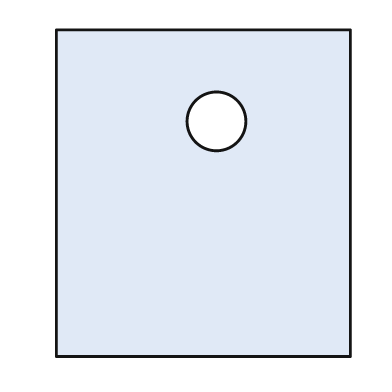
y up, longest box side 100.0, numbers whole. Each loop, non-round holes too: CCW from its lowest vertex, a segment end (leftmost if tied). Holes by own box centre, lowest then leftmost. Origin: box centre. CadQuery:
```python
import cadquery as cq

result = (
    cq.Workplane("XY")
    .moveTo(-45.0, -50.0)
    .lineTo(45.0, -50.0)
    .lineTo(45.0, 50.0)
    .lineTo(-45.0, 50.0)
    .close()
    .moveTo(4.0, 22.0)
    .circle(9.0)
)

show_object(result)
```